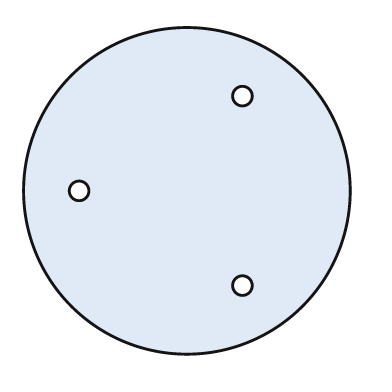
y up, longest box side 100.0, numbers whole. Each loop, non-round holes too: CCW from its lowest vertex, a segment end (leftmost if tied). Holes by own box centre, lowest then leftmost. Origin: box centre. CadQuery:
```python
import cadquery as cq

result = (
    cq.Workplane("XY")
    .moveTo(0.0, 0.0)
    .circle(50.0)
    .moveTo(17.0, -29.0)
    .circle(3.0)
    .moveTo(-33.0, 0.0)
    .circle(3.0)
    .moveTo(17.0, 29.0)
    .circle(3.0)
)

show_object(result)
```